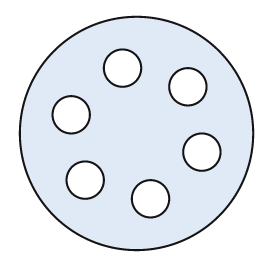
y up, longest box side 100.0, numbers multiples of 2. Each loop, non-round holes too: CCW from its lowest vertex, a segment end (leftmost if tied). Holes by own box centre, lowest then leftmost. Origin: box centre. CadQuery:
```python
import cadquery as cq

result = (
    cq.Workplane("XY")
    .moveTo(0.0, 0.0)
    .circle(50.0)
    .moveTo(6.0, -28.0)
    .circle(8.0)
    .moveTo(-22.0, -20.0)
    .circle(8.0)
    .moveTo(28.0, -8.0)
    .circle(8.0)
    .moveTo(-28.0, 8.0)
    .circle(8.0)
    .moveTo(22.0, 20.0)
    .circle(8.0)
    .moveTo(-6.0, 28.0)
    .circle(8.0)
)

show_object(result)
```